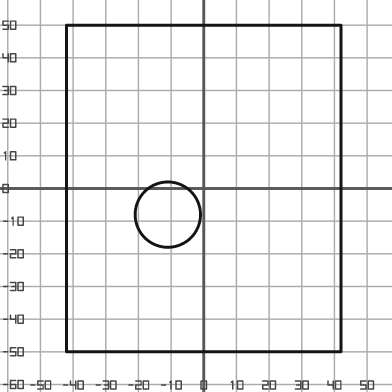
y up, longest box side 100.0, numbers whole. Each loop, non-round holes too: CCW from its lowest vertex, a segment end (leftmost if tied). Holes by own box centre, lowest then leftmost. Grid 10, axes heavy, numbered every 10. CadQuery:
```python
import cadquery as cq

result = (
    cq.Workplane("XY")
    .moveTo(-42.0, -50.0)
    .lineTo(42.0, -50.0)
    .lineTo(42.0, 50.0)
    .lineTo(-42.0, 50.0)
    .close()
    .moveTo(-11.0, -8.0)
    .circle(10.0)
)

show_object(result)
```